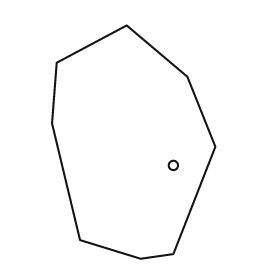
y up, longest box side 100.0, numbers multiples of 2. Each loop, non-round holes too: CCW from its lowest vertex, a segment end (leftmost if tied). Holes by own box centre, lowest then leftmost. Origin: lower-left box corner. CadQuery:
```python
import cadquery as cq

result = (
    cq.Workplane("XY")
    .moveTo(38.0, 0.0)
    .lineTo(52.0, 2.0)
    .lineTo(70.0, 48.0)
    .lineTo(58.0, 78.0)
    .lineTo(32.0, 100.0)
    .lineTo(2.0, 84.0)
    .lineTo(0.0, 58.0)
    .lineTo(12.0, 8.0)
    .close()
    .moveTo(52.0, 40.0)
    .circle(2.0)
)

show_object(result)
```